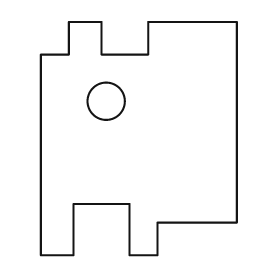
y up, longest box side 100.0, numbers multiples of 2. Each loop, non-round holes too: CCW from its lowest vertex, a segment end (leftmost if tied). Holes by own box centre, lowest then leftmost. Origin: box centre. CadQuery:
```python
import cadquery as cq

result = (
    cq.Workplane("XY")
    .moveTo(-42.0, -50.0)
    .lineTo(-28.0, -50.0)
    .lineTo(-28.0, -28.0)
    .lineTo(-4.0, -28.0)
    .lineTo(-4.0, -50.0)
    .lineTo(8.0, -50.0)
    .lineTo(8.0, -36.0)
    .lineTo(42.0, -36.0)
    .lineTo(42.0, 50.0)
    .lineTo(4.0, 50.0)
    .lineTo(4.0, 36.0)
    .lineTo(-16.0, 36.0)
    .lineTo(-16.0, 50.0)
    .lineTo(-30.0, 50.0)
    .lineTo(-30.0, 36.0)
    .lineTo(-42.0, 36.0)
    .close()
    .moveTo(-14.0, 16.0)
    .circle(8.0)
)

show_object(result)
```